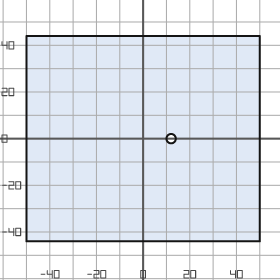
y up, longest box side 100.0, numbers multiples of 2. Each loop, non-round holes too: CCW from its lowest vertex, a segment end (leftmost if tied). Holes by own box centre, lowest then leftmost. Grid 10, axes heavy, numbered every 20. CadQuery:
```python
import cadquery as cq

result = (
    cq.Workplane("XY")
    .moveTo(-50.0, -44.0)
    .lineTo(50.0, -44.0)
    .lineTo(50.0, 44.0)
    .lineTo(-50.0, 44.0)
    .close()
    .moveTo(12.0, 0.0)
    .circle(2.0)
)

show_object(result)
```